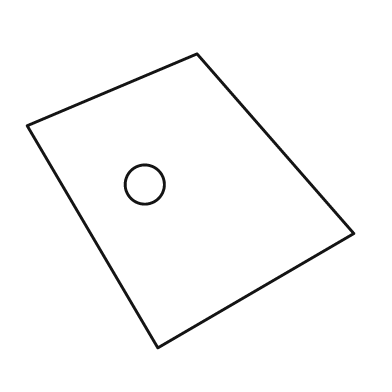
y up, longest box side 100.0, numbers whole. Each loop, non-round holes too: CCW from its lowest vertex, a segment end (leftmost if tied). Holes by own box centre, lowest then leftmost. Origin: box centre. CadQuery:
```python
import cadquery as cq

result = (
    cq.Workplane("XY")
    .moveTo(-10.0, -45.0)
    .lineTo(50.0, -10.0)
    .lineTo(2.0, 45.0)
    .lineTo(-50.0, 23.0)
    .close()
    .moveTo(-14.0, 5.0)
    .circle(6.0)
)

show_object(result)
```